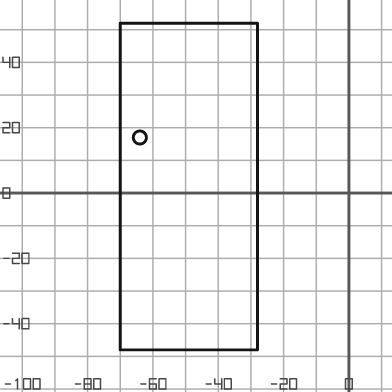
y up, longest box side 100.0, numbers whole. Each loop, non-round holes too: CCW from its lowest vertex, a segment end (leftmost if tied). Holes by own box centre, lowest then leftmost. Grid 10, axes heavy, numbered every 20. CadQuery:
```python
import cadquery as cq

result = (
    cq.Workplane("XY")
    .moveTo(-70.0, -48.0)
    .lineTo(-28.0, -48.0)
    .lineTo(-28.0, 52.0)
    .lineTo(-70.0, 52.0)
    .close()
    .moveTo(-64.0, 17.0)
    .circle(2.0)
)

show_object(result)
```